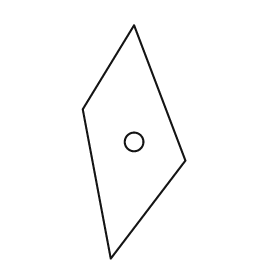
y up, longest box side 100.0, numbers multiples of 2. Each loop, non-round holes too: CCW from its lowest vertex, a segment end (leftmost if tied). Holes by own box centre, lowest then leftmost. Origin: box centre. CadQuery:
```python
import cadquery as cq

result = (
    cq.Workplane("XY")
    .moveTo(-10.0, -50.0)
    .lineTo(22.0, -8.0)
    .lineTo(0.0, 50.0)
    .lineTo(-22.0, 14.0)
    .close()
    .moveTo(0.0, 0.0)
    .circle(4.0)
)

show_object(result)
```